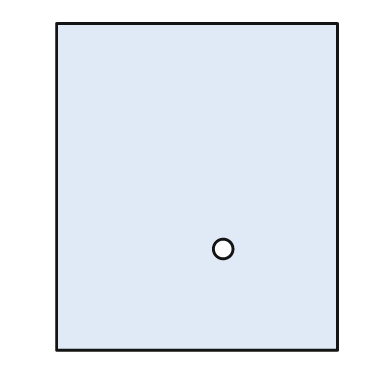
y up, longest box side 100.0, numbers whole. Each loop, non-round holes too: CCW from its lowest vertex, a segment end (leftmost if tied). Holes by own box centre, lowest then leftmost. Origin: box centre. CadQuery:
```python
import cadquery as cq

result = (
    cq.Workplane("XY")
    .moveTo(-43.0, -50.0)
    .lineTo(43.0, -50.0)
    .lineTo(43.0, 50.0)
    .lineTo(-43.0, 50.0)
    .close()
    .moveTo(8.0, -19.0)
    .circle(3.0)
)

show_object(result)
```